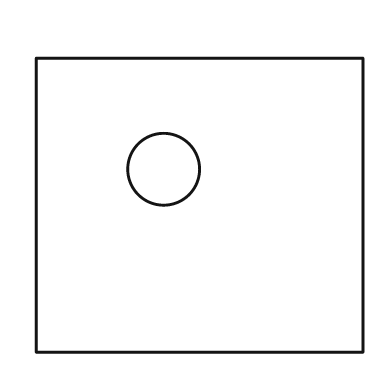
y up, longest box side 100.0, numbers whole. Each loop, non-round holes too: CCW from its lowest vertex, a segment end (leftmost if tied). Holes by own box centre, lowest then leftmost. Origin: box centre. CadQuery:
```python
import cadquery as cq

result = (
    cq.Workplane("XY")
    .moveTo(-50.0, -45.0)
    .lineTo(50.0, -45.0)
    .lineTo(50.0, 45.0)
    .lineTo(-50.0, 45.0)
    .close()
    .moveTo(-11.0, 11.0)
    .circle(11.0)
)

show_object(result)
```